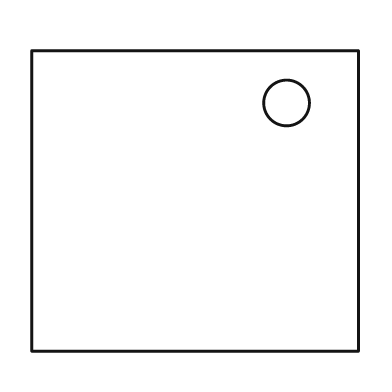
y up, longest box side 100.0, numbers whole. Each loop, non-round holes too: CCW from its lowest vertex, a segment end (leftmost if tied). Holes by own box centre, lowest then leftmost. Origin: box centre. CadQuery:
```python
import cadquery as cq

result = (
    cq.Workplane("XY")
    .moveTo(-50.0, -46.0)
    .lineTo(50.0, -46.0)
    .lineTo(50.0, 46.0)
    .lineTo(-50.0, 46.0)
    .close()
    .moveTo(28.0, 30.0)
    .circle(7.0)
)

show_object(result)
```